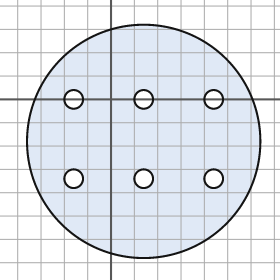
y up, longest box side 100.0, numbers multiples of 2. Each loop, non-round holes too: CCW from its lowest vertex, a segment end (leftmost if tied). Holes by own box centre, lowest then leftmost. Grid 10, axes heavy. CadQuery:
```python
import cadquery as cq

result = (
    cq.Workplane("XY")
    .moveTo(14.0, -18.0)
    .circle(50.0)
    .moveTo(-16.0, -34.0)
    .circle(4.0)
    .moveTo(14.0, -34.0)
    .circle(4.0)
    .moveTo(44.0, -34.0)
    .circle(4.0)
    .moveTo(-16.0, 0.0)
    .circle(4.0)
    .moveTo(14.0, 0.0)
    .circle(4.0)
    .moveTo(44.0, 0.0)
    .circle(4.0)
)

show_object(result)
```